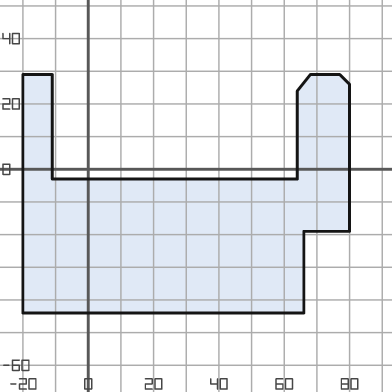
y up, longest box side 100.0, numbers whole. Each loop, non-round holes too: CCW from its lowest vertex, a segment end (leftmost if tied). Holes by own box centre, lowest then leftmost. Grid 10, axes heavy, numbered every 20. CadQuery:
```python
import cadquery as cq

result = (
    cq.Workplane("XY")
    .moveTo(-20.0, -44.0)
    .lineTo(66.0, -44.0)
    .lineTo(66.0, -19.0)
    .lineTo(80.0, -19.0)
    .lineTo(80.0, 26.0)
    .lineTo(77.0, 29.0)
    .lineTo(68.0, 29.0)
    .lineTo(64.0, 24.0)
    .lineTo(64.0, -3.0)
    .lineTo(-11.0, -3.0)
    .lineTo(-11.0, 29.0)
    .lineTo(-20.0, 29.0)
    .close()
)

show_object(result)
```